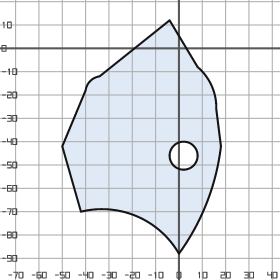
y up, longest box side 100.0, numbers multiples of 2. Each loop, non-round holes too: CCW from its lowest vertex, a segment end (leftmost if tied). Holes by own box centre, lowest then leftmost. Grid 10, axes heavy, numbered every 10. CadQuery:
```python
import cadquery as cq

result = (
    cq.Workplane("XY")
    .moveTo(0.0, -88.0)
    .threePointArc((12.0, -66.0), (18.0, -42.0))
    .lineTo(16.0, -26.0)
    .threePointArc((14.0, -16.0), (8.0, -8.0))
    .lineTo(-4.0, 12.0)
    .lineTo(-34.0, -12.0)
    .threePointArc((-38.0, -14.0), (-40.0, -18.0))
    .lineTo(-50.0, -42.0)
    .lineTo(-42.0, -70.0)
    .threePointArc((-18.0, -72.0), (0.0, -88.0))
    .close()
    .moveTo(2.0, -46.0)
    .circle(6.0)
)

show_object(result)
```